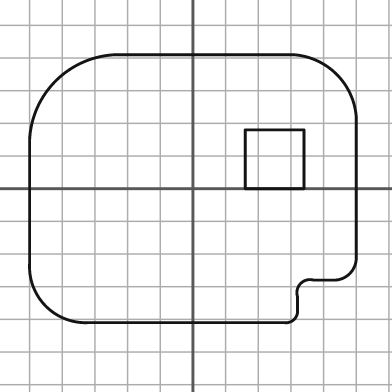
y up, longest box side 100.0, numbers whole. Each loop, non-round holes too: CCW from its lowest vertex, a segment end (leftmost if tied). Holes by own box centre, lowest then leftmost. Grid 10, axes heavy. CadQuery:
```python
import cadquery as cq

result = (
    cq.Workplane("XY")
    .moveTo(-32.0, -41.0)
    .lineTo(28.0, -41.0)
    .threePointArc((31.0, -40.0), (32.0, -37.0))
    .lineTo(32.0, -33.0)
    .threePointArc((33.0, -29.0), (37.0, -28.0))
    .lineTo(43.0, -28.0)
    .threePointArc((48.0, -26.0), (50.0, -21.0))
    .lineTo(50.0, 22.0)
    .threePointArc((44.0, 35.0), (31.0, 41.0))
    .lineTo(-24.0, 41.0)
    .threePointArc((-42.0, 33.0), (-50.0, 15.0))
    .lineTo(-50.0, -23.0)
    .threePointArc((-45.0, -36.0), (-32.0, -41.0))
    .close()
    .moveTo(16.0, 0.0)
    .lineTo(34.0, 0.0)
    .lineTo(34.0, 18.0)
    .lineTo(16.0, 18.0)
    .close()
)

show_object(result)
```